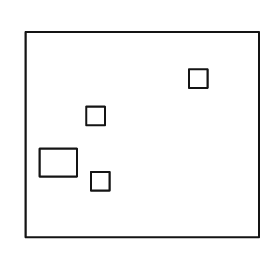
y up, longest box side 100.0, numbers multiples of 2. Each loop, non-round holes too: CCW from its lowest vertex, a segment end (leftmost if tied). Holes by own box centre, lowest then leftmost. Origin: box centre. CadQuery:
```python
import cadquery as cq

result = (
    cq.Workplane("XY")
    .moveTo(-50.0, -44.0)
    .lineTo(50.0, -44.0)
    .lineTo(50.0, 44.0)
    .lineTo(-50.0, 44.0)
    .close()
    .moveTo(-22.0, -24.0)
    .lineTo(-14.0, -24.0)
    .lineTo(-14.0, -16.0)
    .lineTo(-22.0, -16.0)
    .close()
    .moveTo(-44.0, -18.0)
    .lineTo(-28.0, -18.0)
    .lineTo(-28.0, -6.0)
    .lineTo(-44.0, -6.0)
    .close()
    .moveTo(-24.0, 4.0)
    .lineTo(-16.0, 4.0)
    .lineTo(-16.0, 12.0)
    .lineTo(-24.0, 12.0)
    .close()
    .moveTo(20.0, 20.0)
    .lineTo(28.0, 20.0)
    .lineTo(28.0, 28.0)
    .lineTo(20.0, 28.0)
    .close()
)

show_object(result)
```